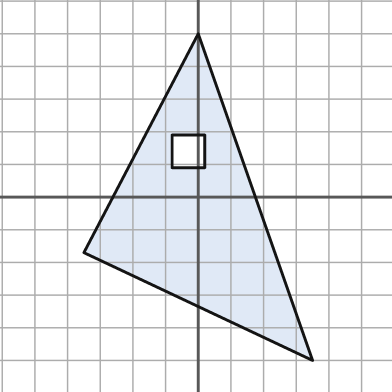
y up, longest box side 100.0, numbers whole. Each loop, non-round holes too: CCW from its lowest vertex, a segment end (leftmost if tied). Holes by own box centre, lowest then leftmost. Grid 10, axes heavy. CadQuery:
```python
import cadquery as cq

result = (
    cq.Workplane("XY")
    .moveTo(35.0, -50.0)
    .lineTo(0.0, 50.0)
    .lineTo(-35.0, -17.0)
    .close()
    .moveTo(-8.0, 9.0)
    .lineTo(2.0, 9.0)
    .lineTo(2.0, 19.0)
    .lineTo(-8.0, 19.0)
    .close()
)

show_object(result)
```